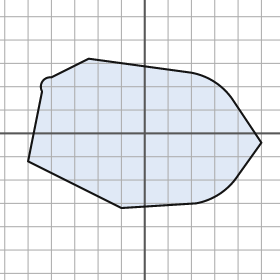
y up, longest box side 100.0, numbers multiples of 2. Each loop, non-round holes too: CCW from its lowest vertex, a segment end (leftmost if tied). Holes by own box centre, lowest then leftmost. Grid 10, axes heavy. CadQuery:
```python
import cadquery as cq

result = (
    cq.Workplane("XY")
    .moveTo(-10.0, -32.0)
    .lineTo(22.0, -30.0)
    .threePointArc((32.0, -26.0), (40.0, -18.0))
    .lineTo(50.0, -4.0)
    .lineTo(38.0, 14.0)
    .threePointArc((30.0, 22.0), (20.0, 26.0))
    .lineTo(-24.0, 32.0)
    .lineTo(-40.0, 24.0)
    .threePointArc((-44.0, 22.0), (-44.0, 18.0))
    .lineTo(-50.0, -12.0)
    .close()
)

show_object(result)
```